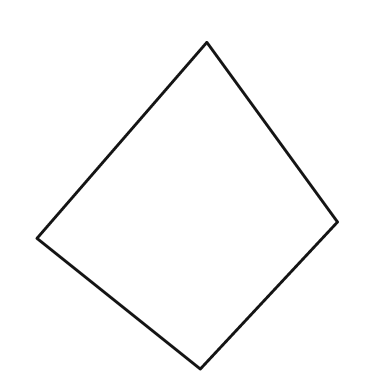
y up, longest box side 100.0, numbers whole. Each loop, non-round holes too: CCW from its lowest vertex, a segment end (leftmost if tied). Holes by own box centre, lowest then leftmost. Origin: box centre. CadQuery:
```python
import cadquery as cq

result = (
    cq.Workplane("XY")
    .moveTo(4.0, -50.0)
    .lineTo(46.0, -5.0)
    .lineTo(6.0, 50.0)
    .lineTo(-46.0, -10.0)
    .close()
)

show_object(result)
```